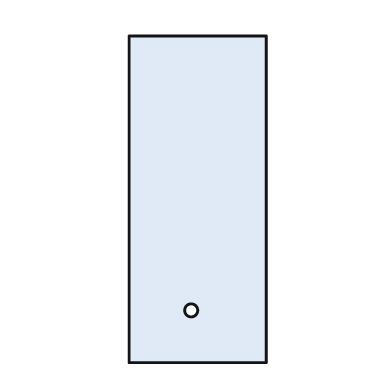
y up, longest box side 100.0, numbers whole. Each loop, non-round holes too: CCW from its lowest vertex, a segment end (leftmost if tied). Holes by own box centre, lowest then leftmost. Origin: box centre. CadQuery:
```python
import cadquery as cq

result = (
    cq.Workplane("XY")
    .moveTo(-21.0, -50.0)
    .lineTo(21.0, -50.0)
    .lineTo(21.0, 50.0)
    .lineTo(-21.0, 50.0)
    .close()
    .moveTo(-2.0, -34.0)
    .circle(2.0)
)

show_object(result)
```